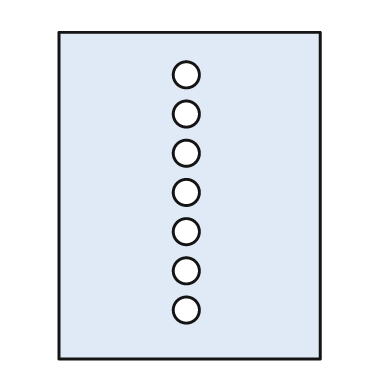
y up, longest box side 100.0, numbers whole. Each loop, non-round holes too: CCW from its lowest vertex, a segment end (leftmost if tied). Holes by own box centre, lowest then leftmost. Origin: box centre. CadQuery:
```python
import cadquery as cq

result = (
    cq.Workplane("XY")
    .moveTo(-40.0, -50.0)
    .lineTo(40.0, -50.0)
    .lineTo(40.0, 50.0)
    .lineTo(-40.0, 50.0)
    .close()
    .moveTo(-1.0, -35.0)
    .circle(4.0)
    .moveTo(-1.0, -23.0)
    .circle(4.0)
    .moveTo(-1.0, -11.0)
    .circle(4.0)
    .moveTo(-1.0, 1.0)
    .circle(4.0)
    .moveTo(-1.0, 13.0)
    .circle(4.0)
    .moveTo(-1.0, 25.0)
    .circle(4.0)
    .moveTo(-1.0, 37.0)
    .circle(4.0)
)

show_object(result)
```